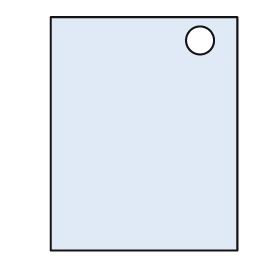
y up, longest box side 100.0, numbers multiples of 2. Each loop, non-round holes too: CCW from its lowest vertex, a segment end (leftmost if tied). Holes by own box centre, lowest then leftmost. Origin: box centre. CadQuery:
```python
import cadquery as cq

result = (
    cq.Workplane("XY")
    .moveTo(-40.0, -50.0)
    .lineTo(40.0, -50.0)
    .lineTo(40.0, 50.0)
    .lineTo(-40.0, 50.0)
    .close()
    .moveTo(24.0, 40.0)
    .circle(6.0)
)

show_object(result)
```